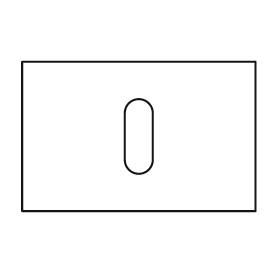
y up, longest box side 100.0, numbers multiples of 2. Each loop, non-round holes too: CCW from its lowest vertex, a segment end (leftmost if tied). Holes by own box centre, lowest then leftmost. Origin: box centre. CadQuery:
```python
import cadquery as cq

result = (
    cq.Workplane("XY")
    .moveTo(-50.0, -32.0)
    .lineTo(50.0, -32.0)
    .lineTo(50.0, 32.0)
    .lineTo(-50.0, 32.0)
    .close()
    .moveTo(-6.0, -10.0)
    .threePointArc((0.0, -16.0), (6.0, -10.0))
    .lineTo(6.0, 10.0)
    .threePointArc((0.0, 16.0), (-6.0, 10.0))
    .close()
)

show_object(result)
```